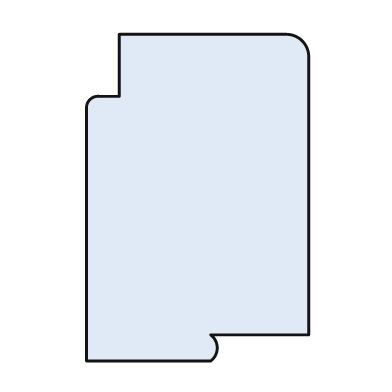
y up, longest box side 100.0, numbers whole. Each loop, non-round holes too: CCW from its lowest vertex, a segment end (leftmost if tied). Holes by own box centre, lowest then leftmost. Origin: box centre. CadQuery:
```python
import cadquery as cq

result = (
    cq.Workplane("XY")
    .moveTo(-34.0, -50.0)
    .lineTo(4.0, -50.0)
    .threePointArc((6.0, -46.0), (4.0, -42.0))
    .lineTo(34.0, -42.0)
    .lineTo(34.0, 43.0)
    .threePointArc((32.0, 48.0), (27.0, 50.0))
    .lineTo(-24.0, 50.0)
    .lineTo(-24.0, 31.0)
    .lineTo(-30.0, 31.0)
    .threePointArc((-33.0, 30.0), (-34.0, 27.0))
    .close()
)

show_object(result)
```